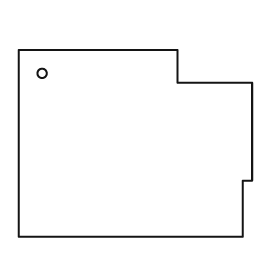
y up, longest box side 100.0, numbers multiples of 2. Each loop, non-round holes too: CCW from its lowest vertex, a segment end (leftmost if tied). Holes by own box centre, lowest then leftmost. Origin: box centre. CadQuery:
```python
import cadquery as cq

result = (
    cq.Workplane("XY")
    .moveTo(-50.0, -40.0)
    .lineTo(46.0, -40.0)
    .lineTo(46.0, -16.0)
    .lineTo(50.0, -16.0)
    .lineTo(50.0, 26.0)
    .lineTo(18.0, 26.0)
    .lineTo(18.0, 40.0)
    .lineTo(-50.0, 40.0)
    .close()
    .moveTo(-40.0, 30.0)
    .circle(2.0)
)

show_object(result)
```